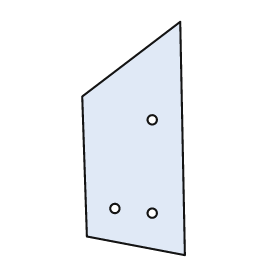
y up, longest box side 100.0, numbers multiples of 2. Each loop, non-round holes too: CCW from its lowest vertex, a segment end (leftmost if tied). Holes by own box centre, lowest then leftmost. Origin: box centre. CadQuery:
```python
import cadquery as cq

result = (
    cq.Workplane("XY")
    .moveTo(22.0, -50.0)
    .lineTo(20.0, 50.0)
    .lineTo(-22.0, 18.0)
    .lineTo(-20.0, -42.0)
    .close()
    .moveTo(8.0, -32.0)
    .circle(2.0)
    .moveTo(-8.0, -30.0)
    .circle(2.0)
    .moveTo(8.0, 8.0)
    .circle(2.0)
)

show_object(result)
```